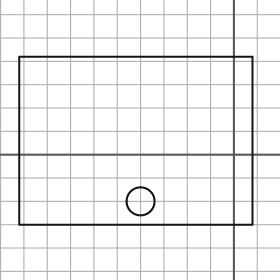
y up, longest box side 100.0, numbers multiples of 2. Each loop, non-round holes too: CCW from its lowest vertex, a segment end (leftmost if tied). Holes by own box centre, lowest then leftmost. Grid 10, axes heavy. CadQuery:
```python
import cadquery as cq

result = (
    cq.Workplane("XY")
    .moveTo(-92.0, -30.0)
    .lineTo(8.0, -30.0)
    .lineTo(8.0, 42.0)
    .lineTo(-92.0, 42.0)
    .close()
    .moveTo(-40.0, -20.0)
    .circle(6.0)
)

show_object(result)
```